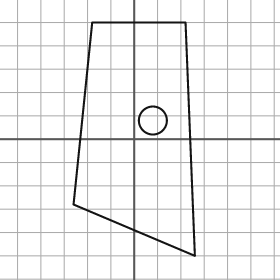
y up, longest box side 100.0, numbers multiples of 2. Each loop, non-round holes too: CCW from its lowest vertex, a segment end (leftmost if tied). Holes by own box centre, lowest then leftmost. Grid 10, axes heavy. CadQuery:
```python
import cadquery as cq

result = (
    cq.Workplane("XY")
    .moveTo(26.0, -50.0)
    .lineTo(22.0, 50.0)
    .lineTo(-18.0, 50.0)
    .lineTo(-26.0, -28.0)
    .close()
    .moveTo(8.0, 8.0)
    .circle(6.0)
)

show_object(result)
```